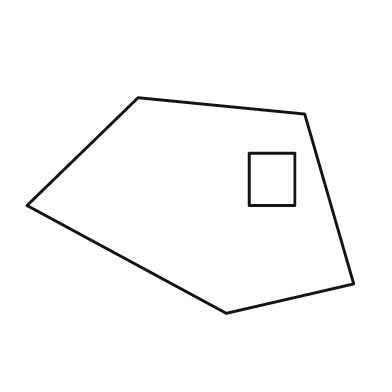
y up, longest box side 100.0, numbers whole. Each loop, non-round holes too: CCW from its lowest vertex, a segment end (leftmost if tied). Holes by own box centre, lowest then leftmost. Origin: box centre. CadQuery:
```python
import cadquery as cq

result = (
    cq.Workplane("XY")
    .moveTo(11.0, -33.0)
    .lineTo(50.0, -24.0)
    .lineTo(35.0, 28.0)
    .lineTo(-16.0, 33.0)
    .lineTo(-50.0, 0.0)
    .close()
    .moveTo(18.0, 0.0)
    .lineTo(32.0, 0.0)
    .lineTo(32.0, 16.0)
    .lineTo(18.0, 16.0)
    .close()
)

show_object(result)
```